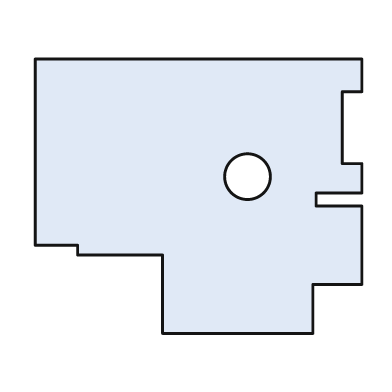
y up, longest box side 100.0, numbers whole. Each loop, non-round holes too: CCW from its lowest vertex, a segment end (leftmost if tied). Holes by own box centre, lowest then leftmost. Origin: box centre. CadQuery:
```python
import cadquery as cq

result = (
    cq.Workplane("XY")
    .moveTo(-11.0, -42.0)
    .lineTo(35.0, -42.0)
    .lineTo(35.0, -27.0)
    .lineTo(50.0, -27.0)
    .lineTo(50.0, -3.0)
    .lineTo(36.0, -3.0)
    .lineTo(36.0, 1.0)
    .lineTo(50.0, 1.0)
    .lineTo(50.0, 10.0)
    .lineTo(44.0, 10.0)
    .lineTo(44.0, 32.0)
    .lineTo(50.0, 32.0)
    .lineTo(50.0, 42.0)
    .lineTo(-50.0, 42.0)
    .lineTo(-50.0, -15.0)
    .lineTo(-37.0, -15.0)
    .lineTo(-37.0, -18.0)
    .lineTo(-11.0, -18.0)
    .close()
    .moveTo(15.0, 6.0)
    .circle(7.0)
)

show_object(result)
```